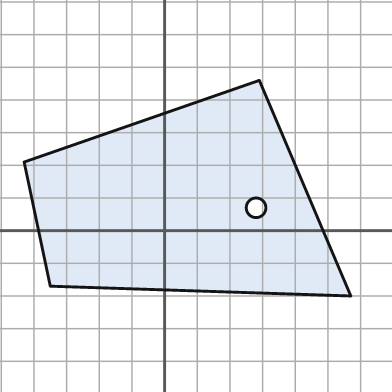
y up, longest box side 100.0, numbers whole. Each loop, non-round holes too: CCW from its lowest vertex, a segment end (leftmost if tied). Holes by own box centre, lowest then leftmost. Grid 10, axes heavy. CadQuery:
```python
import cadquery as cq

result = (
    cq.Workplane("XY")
    .moveTo(57.0, -20.0)
    .lineTo(29.0, 46.0)
    .lineTo(-43.0, 21.0)
    .lineTo(-35.0, -17.0)
    .close()
    .moveTo(28.0, 7.0)
    .circle(3.0)
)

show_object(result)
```